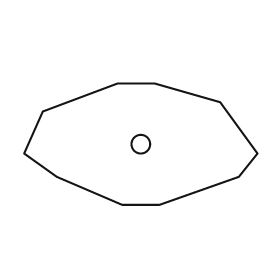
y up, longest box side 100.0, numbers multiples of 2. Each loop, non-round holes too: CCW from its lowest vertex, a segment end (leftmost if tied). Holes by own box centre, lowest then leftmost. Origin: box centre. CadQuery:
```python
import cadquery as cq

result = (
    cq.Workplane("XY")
    .moveTo(-8.0, -26.0)
    .lineTo(8.0, -26.0)
    .lineTo(42.0, -14.0)
    .lineTo(50.0, -4.0)
    .lineTo(34.0, 18.0)
    .lineTo(6.0, 26.0)
    .lineTo(-10.0, 26.0)
    .lineTo(-42.0, 14.0)
    .lineTo(-50.0, -4.0)
    .lineTo(-36.0, -14.0)
    .close()
    .moveTo(0.0, 0.0)
    .circle(4.0)
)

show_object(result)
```